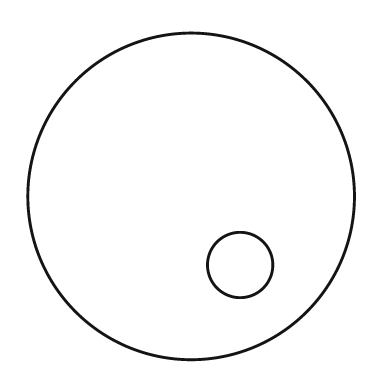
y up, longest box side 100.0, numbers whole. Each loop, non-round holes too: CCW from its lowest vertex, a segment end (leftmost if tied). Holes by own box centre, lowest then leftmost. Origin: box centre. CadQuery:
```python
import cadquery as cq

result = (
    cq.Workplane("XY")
    .moveTo(0.0, 0.0)
    .circle(50.0)
    .moveTo(15.0, -21.0)
    .circle(10.0)
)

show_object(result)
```